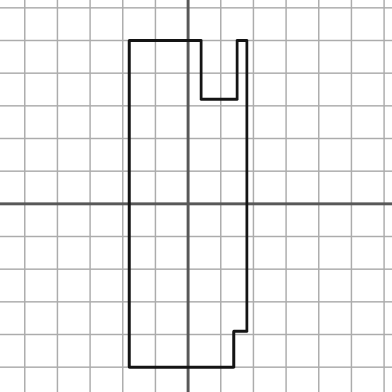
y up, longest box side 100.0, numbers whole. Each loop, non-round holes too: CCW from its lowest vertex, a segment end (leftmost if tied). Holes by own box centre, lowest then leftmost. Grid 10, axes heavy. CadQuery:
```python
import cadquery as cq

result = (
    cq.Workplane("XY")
    .moveTo(-18.0, -50.0)
    .lineTo(14.0, -50.0)
    .lineTo(14.0, -39.0)
    .lineTo(18.0, -39.0)
    .lineTo(18.0, 50.0)
    .lineTo(15.0, 50.0)
    .lineTo(15.0, 32.0)
    .lineTo(4.0, 32.0)
    .lineTo(4.0, 50.0)
    .lineTo(-18.0, 50.0)
    .close()
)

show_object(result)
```